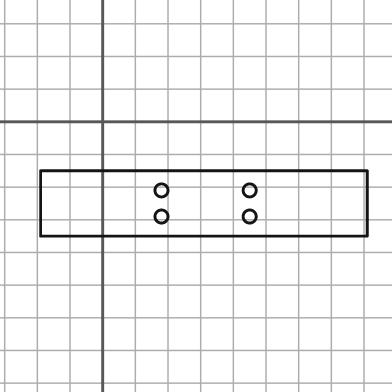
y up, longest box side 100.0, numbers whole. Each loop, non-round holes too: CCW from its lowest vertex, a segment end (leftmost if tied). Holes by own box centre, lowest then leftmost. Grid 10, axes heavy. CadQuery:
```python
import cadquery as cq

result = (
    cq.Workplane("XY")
    .moveTo(-19.0, -35.0)
    .lineTo(81.0, -35.0)
    .lineTo(81.0, -15.0)
    .lineTo(-19.0, -15.0)
    .close()
    .moveTo(18.0, -29.0)
    .circle(2.0)
    .moveTo(45.0, -29.0)
    .circle(2.0)
    .moveTo(18.0, -21.0)
    .circle(2.0)
    .moveTo(45.0, -21.0)
    .circle(2.0)
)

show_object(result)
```